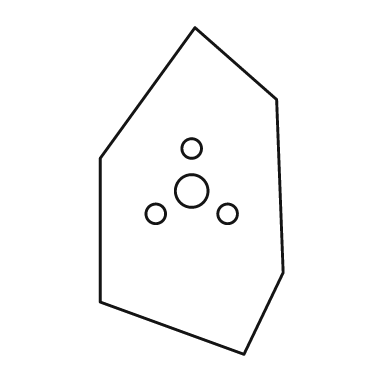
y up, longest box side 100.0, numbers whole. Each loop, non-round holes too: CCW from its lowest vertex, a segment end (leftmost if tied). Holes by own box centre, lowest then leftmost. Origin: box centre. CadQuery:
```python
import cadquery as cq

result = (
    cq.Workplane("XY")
    .moveTo(16.0, -50.0)
    .lineTo(28.0, -25.0)
    .lineTo(26.0, 28.0)
    .lineTo(1.0, 50.0)
    .lineTo(-28.0, 10.0)
    .lineTo(-28.0, -34.0)
    .close()
    .moveTo(-11.0, -7.0)
    .circle(3.0)
    .moveTo(11.0, -7.0)
    .circle(3.0)
    .moveTo(0.0, 0.0)
    .circle(5.0)
    .moveTo(0.0, 13.0)
    .circle(3.0)
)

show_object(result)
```